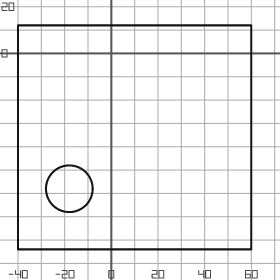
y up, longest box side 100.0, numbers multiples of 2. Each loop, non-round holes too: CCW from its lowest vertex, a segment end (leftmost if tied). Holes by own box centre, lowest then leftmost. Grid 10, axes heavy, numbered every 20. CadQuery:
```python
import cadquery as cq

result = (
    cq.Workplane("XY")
    .moveTo(-40.0, -84.0)
    .lineTo(60.0, -84.0)
    .lineTo(60.0, 12.0)
    .lineTo(-40.0, 12.0)
    .close()
    .moveTo(-18.0, -58.0)
    .circle(10.0)
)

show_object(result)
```